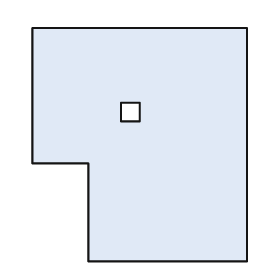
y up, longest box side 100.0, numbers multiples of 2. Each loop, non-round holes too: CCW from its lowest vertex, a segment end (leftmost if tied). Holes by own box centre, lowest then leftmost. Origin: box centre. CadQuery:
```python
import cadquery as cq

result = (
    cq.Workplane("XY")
    .moveTo(-22.0, -50.0)
    .lineTo(46.0, -50.0)
    .lineTo(46.0, 50.0)
    .lineTo(-46.0, 50.0)
    .lineTo(-46.0, -8.0)
    .lineTo(-22.0, -8.0)
    .close()
    .moveTo(-8.0, 10.0)
    .lineTo(0.0, 10.0)
    .lineTo(0.0, 18.0)
    .lineTo(-8.0, 18.0)
    .close()
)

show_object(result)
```